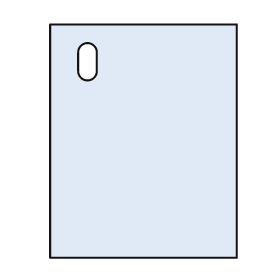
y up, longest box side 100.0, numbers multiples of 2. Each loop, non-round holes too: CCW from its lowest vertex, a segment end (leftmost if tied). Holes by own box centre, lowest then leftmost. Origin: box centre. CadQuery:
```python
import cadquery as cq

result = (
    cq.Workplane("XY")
    .moveTo(-40.0, -50.0)
    .lineTo(40.0, -50.0)
    .lineTo(40.0, 50.0)
    .lineTo(-40.0, 50.0)
    .close()
    .moveTo(-28.0, 30.0)
    .threePointArc((-24.0, 26.0), (-20.0, 30.0))
    .lineTo(-20.0, 38.0)
    .threePointArc((-24.0, 42.0), (-28.0, 38.0))
    .close()
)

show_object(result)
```